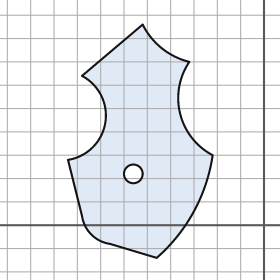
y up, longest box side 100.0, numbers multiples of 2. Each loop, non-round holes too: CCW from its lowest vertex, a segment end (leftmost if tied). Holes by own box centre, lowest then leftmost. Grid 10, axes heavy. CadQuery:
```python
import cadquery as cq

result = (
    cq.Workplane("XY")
    .moveTo(-46.0, -14.0)
    .threePointArc((-30.0, 6.0), (-22.0, 30.0))
    .threePointArc((-36.0, 48.0), (-32.0, 70.0))
    .threePointArc((-44.0, 76.0), (-52.0, 86.0))
    .lineTo(-78.0, 64.0)
    .threePointArc((-68.0, 44.0), (-84.0, 28.0))
    .lineTo(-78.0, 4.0)
    .threePointArc((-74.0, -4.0), (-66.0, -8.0))
    .close()
    .moveTo(-56.0, 22.0)
    .circle(4.0)
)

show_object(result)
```